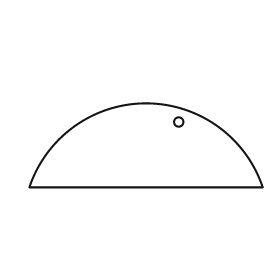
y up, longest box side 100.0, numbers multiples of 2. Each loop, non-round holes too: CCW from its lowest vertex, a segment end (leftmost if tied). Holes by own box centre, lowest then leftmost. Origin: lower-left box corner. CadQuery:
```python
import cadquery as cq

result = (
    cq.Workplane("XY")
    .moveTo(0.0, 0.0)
    .lineTo(100.0, 0.0)
    .threePointArc((50.0, 36.0), (0.0, 0.0))
    .close()
    .moveTo(64.0, 28.0)
    .circle(2.0)
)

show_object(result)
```